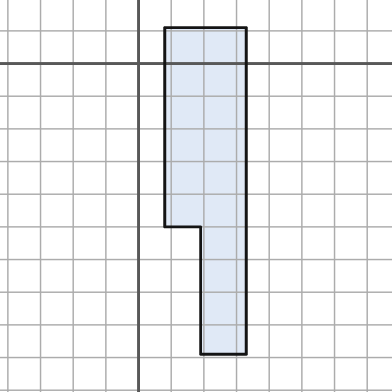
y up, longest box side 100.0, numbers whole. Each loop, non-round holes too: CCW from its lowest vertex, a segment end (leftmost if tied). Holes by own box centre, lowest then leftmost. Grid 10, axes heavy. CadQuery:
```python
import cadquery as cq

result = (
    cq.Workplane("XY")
    .moveTo(19.0, -89.0)
    .lineTo(33.0, -89.0)
    .lineTo(33.0, 11.0)
    .lineTo(8.0, 11.0)
    .lineTo(8.0, -50.0)
    .lineTo(19.0, -50.0)
    .close()
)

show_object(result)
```